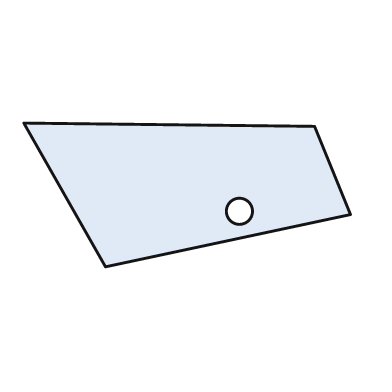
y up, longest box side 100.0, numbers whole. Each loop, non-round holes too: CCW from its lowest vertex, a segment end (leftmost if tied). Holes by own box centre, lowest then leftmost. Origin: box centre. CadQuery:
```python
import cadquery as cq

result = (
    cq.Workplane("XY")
    .moveTo(-25.0, -22.0)
    .lineTo(50.0, -6.0)
    .lineTo(39.0, 21.0)
    .lineTo(-50.0, 22.0)
    .close()
    .moveTo(16.0, -5.0)
    .circle(4.0)
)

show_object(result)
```